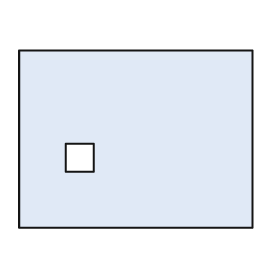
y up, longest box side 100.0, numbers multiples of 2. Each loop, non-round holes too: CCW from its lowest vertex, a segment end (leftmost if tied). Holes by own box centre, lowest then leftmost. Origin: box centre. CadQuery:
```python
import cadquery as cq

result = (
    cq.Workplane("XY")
    .moveTo(-50.0, -38.0)
    .lineTo(50.0, -38.0)
    .lineTo(50.0, 38.0)
    .lineTo(-50.0, 38.0)
    .close()
    .moveTo(-30.0, -14.0)
    .lineTo(-18.0, -14.0)
    .lineTo(-18.0, -2.0)
    .lineTo(-30.0, -2.0)
    .close()
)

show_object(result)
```